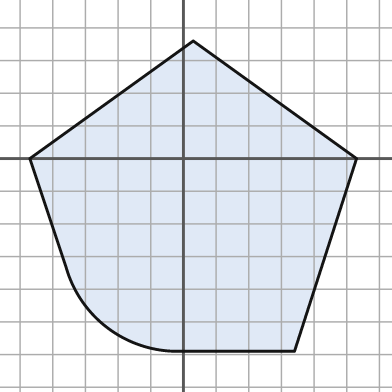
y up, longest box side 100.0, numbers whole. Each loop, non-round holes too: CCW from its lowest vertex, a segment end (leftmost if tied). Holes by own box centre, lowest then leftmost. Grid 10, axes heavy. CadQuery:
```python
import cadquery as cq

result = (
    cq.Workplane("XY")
    .moveTo(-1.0, -59.0)
    .lineTo(34.0, -59.0)
    .lineTo(53.0, 0.0)
    .lineTo(3.0, 36.0)
    .lineTo(-47.0, 0.0)
    .lineTo(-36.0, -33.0)
    .threePointArc((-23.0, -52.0), (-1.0, -59.0))
    .close()
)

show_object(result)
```